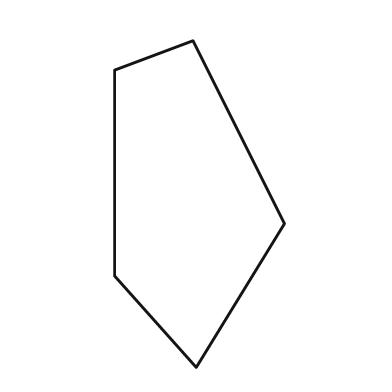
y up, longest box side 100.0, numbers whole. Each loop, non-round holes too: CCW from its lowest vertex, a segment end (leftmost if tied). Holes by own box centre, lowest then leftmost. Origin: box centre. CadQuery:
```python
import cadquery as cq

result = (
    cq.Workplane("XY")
    .moveTo(-1.0, -50.0)
    .lineTo(26.0, -6.0)
    .lineTo(-2.0, 50.0)
    .lineTo(-26.0, 41.0)
    .lineTo(-26.0, -22.0)
    .close()
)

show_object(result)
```